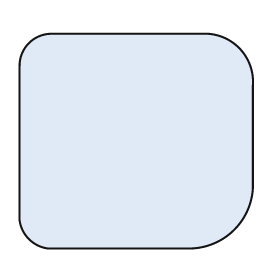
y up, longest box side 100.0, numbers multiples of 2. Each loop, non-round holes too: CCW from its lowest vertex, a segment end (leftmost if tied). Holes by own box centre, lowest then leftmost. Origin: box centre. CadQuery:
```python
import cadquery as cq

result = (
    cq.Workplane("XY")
    .moveTo(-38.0, -46.0)
    .lineTo(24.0, -46.0)
    .threePointArc((42.0, -38.0), (50.0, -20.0))
    .lineTo(50.0, 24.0)
    .threePointArc((44.0, 40.0), (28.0, 46.0))
    .lineTo(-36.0, 46.0)
    .threePointArc((-46.0, 42.0), (-50.0, 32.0))
    .lineTo(-50.0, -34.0)
    .threePointArc((-46.0, -42.0), (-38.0, -46.0))
    .close()
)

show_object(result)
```